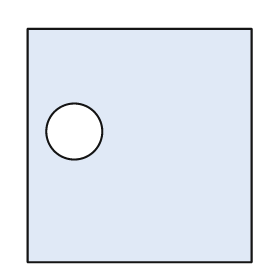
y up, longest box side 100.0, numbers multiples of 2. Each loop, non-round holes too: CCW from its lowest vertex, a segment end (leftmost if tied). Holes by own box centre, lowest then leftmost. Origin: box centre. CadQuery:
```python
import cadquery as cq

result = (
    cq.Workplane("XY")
    .moveTo(-48.0, -50.0)
    .lineTo(48.0, -50.0)
    .lineTo(48.0, 50.0)
    .lineTo(-48.0, 50.0)
    .close()
    .moveTo(-28.0, 6.0)
    .circle(12.0)
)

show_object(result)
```